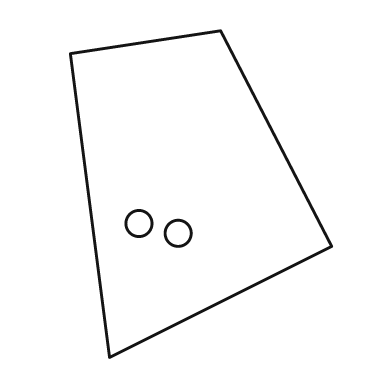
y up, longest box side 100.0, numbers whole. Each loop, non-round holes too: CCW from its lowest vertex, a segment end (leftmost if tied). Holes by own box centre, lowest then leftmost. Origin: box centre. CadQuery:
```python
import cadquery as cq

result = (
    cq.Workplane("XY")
    .moveTo(-28.0, -50.0)
    .lineTo(40.0, -16.0)
    .lineTo(6.0, 50.0)
    .lineTo(-40.0, 43.0)
    .close()
    .moveTo(-7.0, -12.0)
    .circle(4.0)
    .moveTo(-19.0, -9.0)
    .circle(4.0)
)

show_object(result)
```